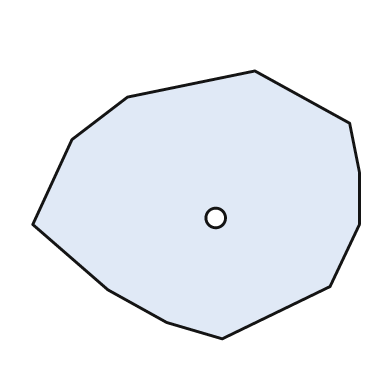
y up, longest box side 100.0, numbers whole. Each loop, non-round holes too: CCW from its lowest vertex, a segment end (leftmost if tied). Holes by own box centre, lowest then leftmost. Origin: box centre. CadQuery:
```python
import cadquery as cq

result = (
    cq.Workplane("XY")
    .moveTo(8.0, -41.0)
    .lineTo(41.0, -25.0)
    .lineTo(50.0, -6.0)
    .lineTo(50.0, 10.0)
    .lineTo(47.0, 25.0)
    .lineTo(18.0, 41.0)
    .lineTo(-21.0, 33.0)
    .lineTo(-38.0, 20.0)
    .lineTo(-50.0, -6.0)
    .lineTo(-27.0, -26.0)
    .lineTo(-9.0, -36.0)
    .close()
    .moveTo(6.0, -4.0)
    .circle(3.0)
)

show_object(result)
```